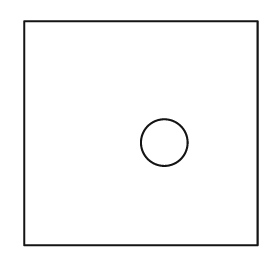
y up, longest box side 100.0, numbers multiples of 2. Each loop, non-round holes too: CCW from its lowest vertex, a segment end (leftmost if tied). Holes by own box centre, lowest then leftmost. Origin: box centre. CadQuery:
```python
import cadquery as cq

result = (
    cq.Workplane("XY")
    .moveTo(-50.0, -48.0)
    .lineTo(50.0, -48.0)
    .lineTo(50.0, 48.0)
    .lineTo(-50.0, 48.0)
    .close()
    .moveTo(10.0, -4.0)
    .circle(10.0)
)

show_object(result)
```